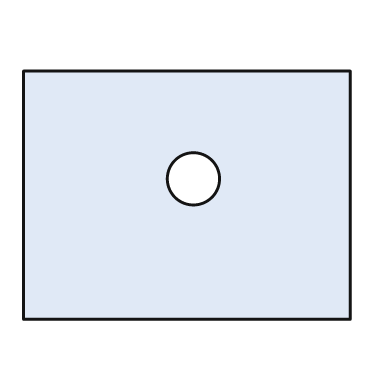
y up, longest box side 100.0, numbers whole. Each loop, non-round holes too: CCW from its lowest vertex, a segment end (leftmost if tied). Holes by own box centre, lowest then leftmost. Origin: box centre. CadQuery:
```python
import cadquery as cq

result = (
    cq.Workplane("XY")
    .moveTo(-50.0, -38.0)
    .lineTo(50.0, -38.0)
    .lineTo(50.0, 38.0)
    .lineTo(-50.0, 38.0)
    .close()
    .moveTo(2.0, 5.0)
    .circle(8.0)
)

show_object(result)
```